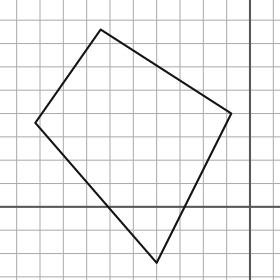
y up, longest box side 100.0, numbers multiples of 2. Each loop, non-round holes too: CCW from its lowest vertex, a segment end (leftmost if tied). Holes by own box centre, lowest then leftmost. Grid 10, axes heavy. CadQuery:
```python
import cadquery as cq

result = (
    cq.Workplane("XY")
    .moveTo(-40.0, -24.0)
    .lineTo(-8.0, 40.0)
    .lineTo(-64.0, 76.0)
    .lineTo(-92.0, 36.0)
    .close()
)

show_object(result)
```